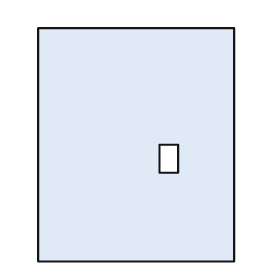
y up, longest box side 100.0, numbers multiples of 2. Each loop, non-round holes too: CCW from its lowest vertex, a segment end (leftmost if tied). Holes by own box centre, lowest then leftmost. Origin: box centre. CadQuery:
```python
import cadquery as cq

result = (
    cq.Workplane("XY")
    .moveTo(-42.0, -50.0)
    .lineTo(42.0, -50.0)
    .lineTo(42.0, 50.0)
    .lineTo(-42.0, 50.0)
    .close()
    .moveTo(10.0, -12.0)
    .lineTo(18.0, -12.0)
    .lineTo(18.0, 0.0)
    .lineTo(10.0, 0.0)
    .close()
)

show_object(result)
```